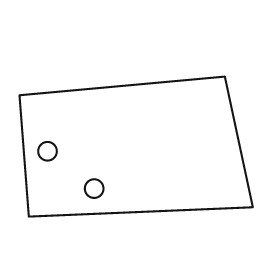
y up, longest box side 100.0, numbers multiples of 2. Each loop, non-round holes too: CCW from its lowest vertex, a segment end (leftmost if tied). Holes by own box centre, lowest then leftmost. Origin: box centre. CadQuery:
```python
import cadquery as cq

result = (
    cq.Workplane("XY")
    .moveTo(-46.0, -30.0)
    .lineTo(50.0, -26.0)
    .lineTo(38.0, 30.0)
    .lineTo(-50.0, 22.0)
    .close()
    .moveTo(-18.0, -18.0)
    .circle(4.0)
    .moveTo(-38.0, -2.0)
    .circle(4.0)
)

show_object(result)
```